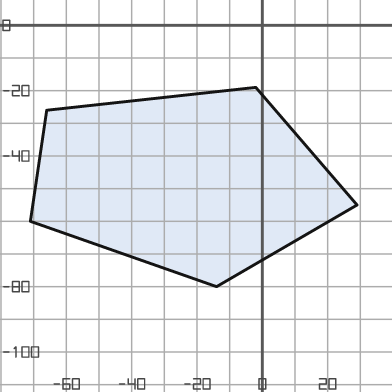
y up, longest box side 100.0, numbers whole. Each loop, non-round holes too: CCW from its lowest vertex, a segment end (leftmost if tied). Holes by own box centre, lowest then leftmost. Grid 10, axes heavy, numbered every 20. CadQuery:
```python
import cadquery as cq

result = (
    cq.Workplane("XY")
    .moveTo(-14.0, -80.0)
    .lineTo(29.0, -55.0)
    .lineTo(-2.0, -19.0)
    .lineTo(-66.0, -26.0)
    .lineTo(-71.0, -60.0)
    .close()
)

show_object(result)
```